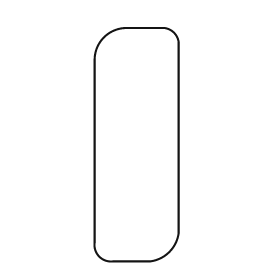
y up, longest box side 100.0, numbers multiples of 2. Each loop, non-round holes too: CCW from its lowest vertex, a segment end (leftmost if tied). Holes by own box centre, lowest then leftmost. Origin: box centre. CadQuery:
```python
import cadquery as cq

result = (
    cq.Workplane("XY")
    .moveTo(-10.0, -50.0)
    .lineTo(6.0, -50.0)
    .threePointArc((14.0, -46.0), (18.0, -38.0))
    .lineTo(18.0, 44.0)
    .threePointArc((16.0, 48.0), (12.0, 50.0))
    .lineTo(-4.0, 50.0)
    .threePointArc((-14.0, 46.0), (-18.0, 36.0))
    .lineTo(-18.0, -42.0)
    .threePointArc((-16.0, -48.0), (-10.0, -50.0))
    .close()
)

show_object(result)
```